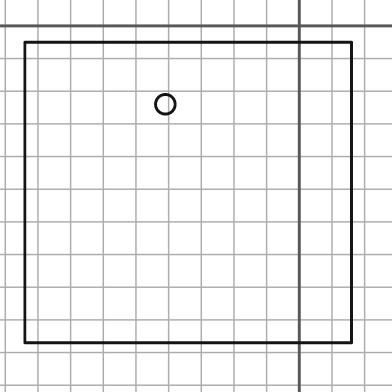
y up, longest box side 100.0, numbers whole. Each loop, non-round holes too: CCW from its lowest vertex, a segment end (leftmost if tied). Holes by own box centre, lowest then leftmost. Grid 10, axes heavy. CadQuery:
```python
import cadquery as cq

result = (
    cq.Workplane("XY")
    .moveTo(-84.0, -97.0)
    .lineTo(16.0, -97.0)
    .lineTo(16.0, -5.0)
    .lineTo(-84.0, -5.0)
    .close()
    .moveTo(-41.0, -24.0)
    .circle(3.0)
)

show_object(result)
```